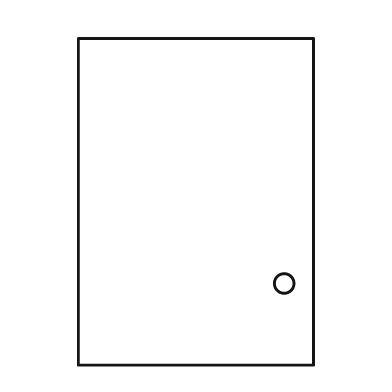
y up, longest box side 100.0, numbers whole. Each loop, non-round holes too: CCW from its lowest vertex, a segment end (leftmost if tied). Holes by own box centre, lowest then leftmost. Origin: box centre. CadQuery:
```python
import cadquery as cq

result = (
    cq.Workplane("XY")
    .moveTo(-36.0, -50.0)
    .lineTo(36.0, -50.0)
    .lineTo(36.0, 50.0)
    .lineTo(-36.0, 50.0)
    .close()
    .moveTo(27.0, -25.0)
    .circle(3.0)
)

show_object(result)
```